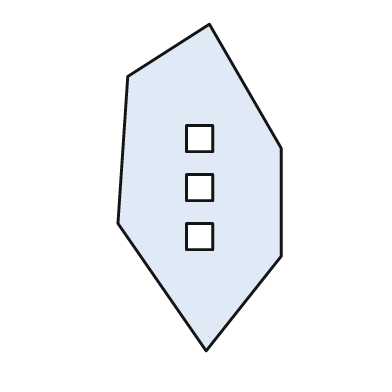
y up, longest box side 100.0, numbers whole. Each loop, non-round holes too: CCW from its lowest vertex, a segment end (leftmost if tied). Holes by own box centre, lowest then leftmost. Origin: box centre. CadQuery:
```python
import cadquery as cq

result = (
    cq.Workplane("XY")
    .moveTo(2.0, -50.0)
    .lineTo(25.0, -21.0)
    .lineTo(25.0, 12.0)
    .lineTo(3.0, 50.0)
    .lineTo(-22.0, 34.0)
    .lineTo(-25.0, -11.0)
    .close()
    .moveTo(-4.0, -19.0)
    .lineTo(4.0, -19.0)
    .lineTo(4.0, -11.0)
    .lineTo(-4.0, -11.0)
    .close()
    .moveTo(-4.0, -4.0)
    .lineTo(4.0, -4.0)
    .lineTo(4.0, 4.0)
    .lineTo(-4.0, 4.0)
    .close()
    .moveTo(-4.0, 11.0)
    .lineTo(4.0, 11.0)
    .lineTo(4.0, 19.0)
    .lineTo(-4.0, 19.0)
    .close()
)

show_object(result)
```